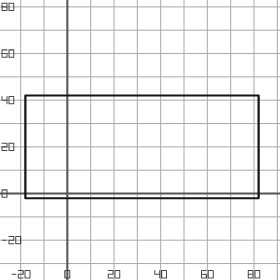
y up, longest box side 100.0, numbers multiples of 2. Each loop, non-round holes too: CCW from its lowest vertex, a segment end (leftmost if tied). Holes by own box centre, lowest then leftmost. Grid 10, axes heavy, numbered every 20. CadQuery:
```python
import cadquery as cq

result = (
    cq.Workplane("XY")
    .moveTo(-18.0, -2.0)
    .lineTo(82.0, -2.0)
    .lineTo(82.0, 42.0)
    .lineTo(-18.0, 42.0)
    .close()
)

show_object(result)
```